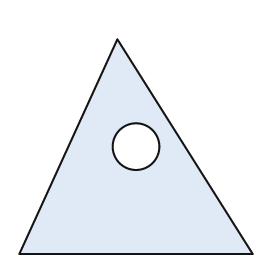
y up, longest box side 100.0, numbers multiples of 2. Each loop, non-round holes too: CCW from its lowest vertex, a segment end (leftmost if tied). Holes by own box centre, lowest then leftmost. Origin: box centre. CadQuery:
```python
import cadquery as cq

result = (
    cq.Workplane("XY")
    .moveTo(-50.0, -46.0)
    .lineTo(50.0, -46.0)
    .lineTo(-8.0, 46.0)
    .close()
    .moveTo(0.0, 0.0)
    .circle(10.0)
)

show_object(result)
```